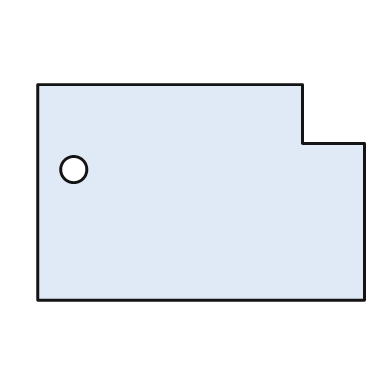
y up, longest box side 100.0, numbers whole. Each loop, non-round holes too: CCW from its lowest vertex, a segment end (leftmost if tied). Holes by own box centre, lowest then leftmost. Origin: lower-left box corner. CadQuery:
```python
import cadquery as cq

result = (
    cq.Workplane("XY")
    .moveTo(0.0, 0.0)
    .lineTo(100.0, 0.0)
    .lineTo(100.0, 48.0)
    .lineTo(81.0, 48.0)
    .lineTo(81.0, 66.0)
    .lineTo(0.0, 66.0)
    .close()
    .moveTo(11.0, 40.0)
    .circle(4.0)
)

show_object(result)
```